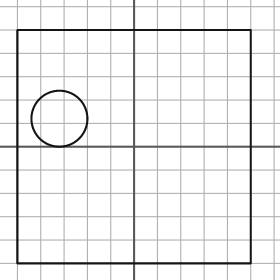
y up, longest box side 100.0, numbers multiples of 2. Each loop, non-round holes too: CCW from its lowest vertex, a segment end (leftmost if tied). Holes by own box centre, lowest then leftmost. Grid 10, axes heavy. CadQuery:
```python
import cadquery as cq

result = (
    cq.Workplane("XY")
    .moveTo(-50.0, -50.0)
    .lineTo(50.0, -50.0)
    .lineTo(50.0, 50.0)
    .lineTo(-50.0, 50.0)
    .close()
    .moveTo(-32.0, 12.0)
    .circle(12.0)
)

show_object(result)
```